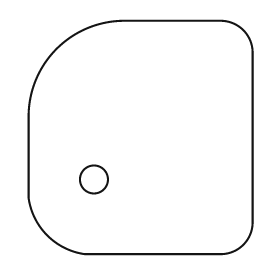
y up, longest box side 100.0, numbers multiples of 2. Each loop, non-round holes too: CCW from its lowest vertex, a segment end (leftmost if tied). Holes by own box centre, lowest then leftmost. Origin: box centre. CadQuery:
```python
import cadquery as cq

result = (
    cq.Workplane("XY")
    .moveTo(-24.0, -50.0)
    .lineTo(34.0, -50.0)
    .threePointArc((44.0, -46.0), (48.0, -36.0))
    .lineTo(48.0, 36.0)
    .threePointArc((44.0, 46.0), (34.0, 50.0))
    .lineTo(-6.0, 50.0)
    .threePointArc((-36.0, 38.0), (-48.0, 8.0))
    .lineTo(-48.0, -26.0)
    .threePointArc((-40.0, -42.0), (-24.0, -50.0))
    .close()
    .moveTo(-20.0, -18.0)
    .circle(6.0)
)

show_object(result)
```